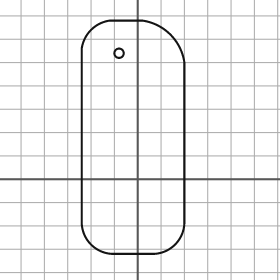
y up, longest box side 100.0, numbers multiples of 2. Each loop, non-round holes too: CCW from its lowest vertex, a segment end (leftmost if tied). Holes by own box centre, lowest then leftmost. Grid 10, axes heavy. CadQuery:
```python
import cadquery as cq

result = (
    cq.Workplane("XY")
    .moveTo(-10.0, -32.0)
    .lineTo(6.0, -32.0)
    .threePointArc((16.0, -28.0), (20.0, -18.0))
    .lineTo(20.0, 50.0)
    .threePointArc((14.0, 62.0), (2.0, 68.0))
    .lineTo(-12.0, 68.0)
    .threePointArc((-20.0, 64.0), (-24.0, 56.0))
    .lineTo(-24.0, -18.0)
    .threePointArc((-20.0, -28.0), (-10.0, -32.0))
    .close()
    .moveTo(-8.0, 54.0)
    .circle(2.0)
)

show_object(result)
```